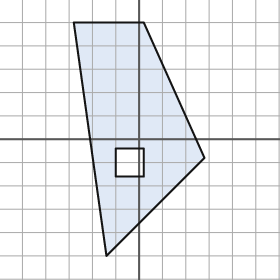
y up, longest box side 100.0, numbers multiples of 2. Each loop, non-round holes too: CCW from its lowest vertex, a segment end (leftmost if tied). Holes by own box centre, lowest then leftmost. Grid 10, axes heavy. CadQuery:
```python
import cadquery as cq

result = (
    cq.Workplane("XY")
    .moveTo(-14.0, -50.0)
    .lineTo(28.0, -8.0)
    .lineTo(2.0, 50.0)
    .lineTo(-28.0, 50.0)
    .close()
    .moveTo(-10.0, -16.0)
    .lineTo(2.0, -16.0)
    .lineTo(2.0, -4.0)
    .lineTo(-10.0, -4.0)
    .close()
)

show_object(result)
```